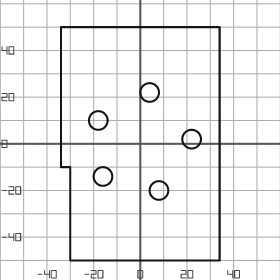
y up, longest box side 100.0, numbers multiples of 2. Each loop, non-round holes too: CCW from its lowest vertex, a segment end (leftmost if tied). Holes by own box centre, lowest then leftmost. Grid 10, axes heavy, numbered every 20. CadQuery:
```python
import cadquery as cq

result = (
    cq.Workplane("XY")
    .moveTo(-30.0, -50.0)
    .lineTo(34.0, -50.0)
    .lineTo(34.0, 50.0)
    .lineTo(-34.0, 50.0)
    .lineTo(-34.0, -10.0)
    .lineTo(-30.0, -10.0)
    .close()
    .moveTo(8.0, -20.0)
    .circle(4.0)
    .moveTo(-16.0, -14.0)
    .circle(4.0)
    .moveTo(22.0, 2.0)
    .circle(4.0)
    .moveTo(-18.0, 10.0)
    .circle(4.0)
    .moveTo(4.0, 22.0)
    .circle(4.0)
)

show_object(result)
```